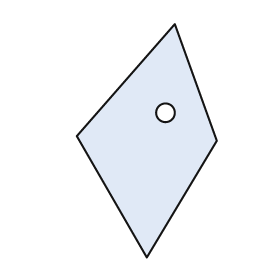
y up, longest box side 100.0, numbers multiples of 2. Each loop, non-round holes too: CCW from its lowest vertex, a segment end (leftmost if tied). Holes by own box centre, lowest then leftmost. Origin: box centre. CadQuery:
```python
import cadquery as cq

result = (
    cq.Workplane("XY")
    .moveTo(0.0, -50.0)
    .lineTo(30.0, 0.0)
    .lineTo(12.0, 50.0)
    .lineTo(-30.0, 2.0)
    .close()
    .moveTo(8.0, 12.0)
    .circle(4.0)
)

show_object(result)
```